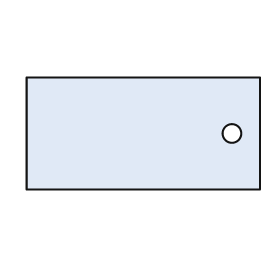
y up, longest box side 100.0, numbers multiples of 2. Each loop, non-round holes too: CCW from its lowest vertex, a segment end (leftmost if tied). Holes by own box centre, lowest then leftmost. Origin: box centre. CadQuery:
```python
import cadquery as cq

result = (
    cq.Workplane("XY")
    .moveTo(-50.0, -24.0)
    .lineTo(50.0, -24.0)
    .lineTo(50.0, 24.0)
    .lineTo(-50.0, 24.0)
    .close()
    .moveTo(38.0, 0.0)
    .circle(4.0)
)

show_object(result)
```